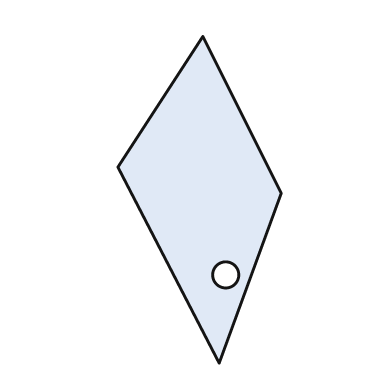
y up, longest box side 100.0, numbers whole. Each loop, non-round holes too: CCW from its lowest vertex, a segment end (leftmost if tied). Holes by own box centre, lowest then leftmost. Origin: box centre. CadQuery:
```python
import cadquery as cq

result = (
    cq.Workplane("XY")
    .moveTo(6.0, -50.0)
    .lineTo(25.0, 2.0)
    .lineTo(1.0, 50.0)
    .lineTo(-25.0, 10.0)
    .close()
    .moveTo(8.0, -23.0)
    .circle(4.0)
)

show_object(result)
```